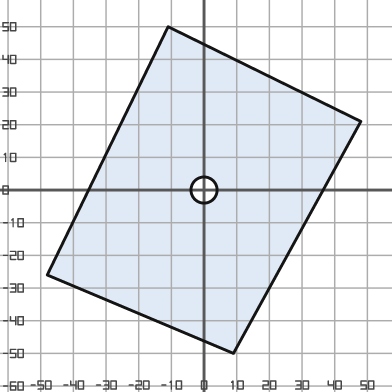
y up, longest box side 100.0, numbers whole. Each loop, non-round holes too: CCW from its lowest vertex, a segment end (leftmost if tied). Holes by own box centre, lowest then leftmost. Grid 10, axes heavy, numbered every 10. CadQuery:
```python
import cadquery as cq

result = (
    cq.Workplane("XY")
    .moveTo(9.0, -50.0)
    .lineTo(48.0, 21.0)
    .lineTo(-11.0, 50.0)
    .lineTo(-48.0, -26.0)
    .close()
    .moveTo(0.0, 0.0)
    .circle(4.0)
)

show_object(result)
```